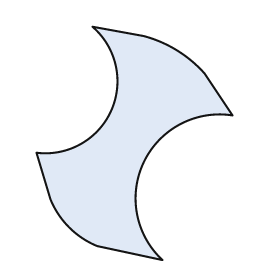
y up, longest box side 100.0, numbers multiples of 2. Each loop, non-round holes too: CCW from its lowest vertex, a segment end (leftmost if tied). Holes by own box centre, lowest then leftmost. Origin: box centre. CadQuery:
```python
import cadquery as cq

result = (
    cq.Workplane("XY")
    .moveTo(12.0, -50.0)
    .threePointArc((4.0, -8.0), (42.0, 12.0))
    .lineTo(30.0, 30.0)
    .threePointArc((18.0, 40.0), (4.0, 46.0))
    .lineTo(-18.0, 50.0)
    .threePointArc((-10.0, 14.0), (-42.0, -4.0))
    .lineTo(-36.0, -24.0)
    .threePointArc((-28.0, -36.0), (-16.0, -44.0))
    .close()
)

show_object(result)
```